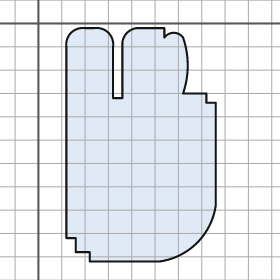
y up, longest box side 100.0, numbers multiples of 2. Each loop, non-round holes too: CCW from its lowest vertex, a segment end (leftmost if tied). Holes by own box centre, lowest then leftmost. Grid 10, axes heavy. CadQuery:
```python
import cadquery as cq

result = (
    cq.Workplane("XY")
    .moveTo(22.0, -102.0)
    .lineTo(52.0, -102.0)
    .threePointArc((68.0, -94.0), (76.0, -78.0))
    .lineTo(76.0, -34.0)
    .lineTo(72.0, -34.0)
    .lineTo(72.0, -30.0)
    .lineTo(62.0, -30.0)
    .threePointArc((64.0, -18.0), (62.0, -6.0))
    .threePointArc((58.0, -4.0), (54.0, -6.0))
    .lineTo(54.0, -2.0)
    .lineTo(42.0, -2.0)
    .threePointArc((38.0, -4.0), (36.0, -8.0))
    .lineTo(36.0, -32.0)
    .lineTo(32.0, -32.0)
    .lineTo(32.0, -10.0)
    .threePointArc((30.0, -4.0), (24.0, -2.0))
    .lineTo(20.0, -2.0)
    .threePointArc((14.0, -4.0), (12.0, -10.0))
    .lineTo(12.0, -92.0)
    .lineTo(16.0, -92.0)
    .lineTo(16.0, -98.0)
    .lineTo(22.0, -98.0)
    .close()
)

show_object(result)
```